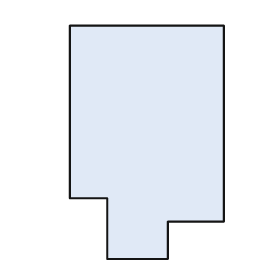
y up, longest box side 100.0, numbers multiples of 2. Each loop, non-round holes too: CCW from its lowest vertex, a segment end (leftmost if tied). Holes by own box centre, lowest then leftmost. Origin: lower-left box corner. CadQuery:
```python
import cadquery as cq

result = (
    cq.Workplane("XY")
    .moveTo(16.0, 0.0)
    .lineTo(42.0, 0.0)
    .lineTo(42.0, 16.0)
    .lineTo(66.0, 16.0)
    .lineTo(66.0, 100.0)
    .lineTo(0.0, 100.0)
    .lineTo(0.0, 26.0)
    .lineTo(16.0, 26.0)
    .close()
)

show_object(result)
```